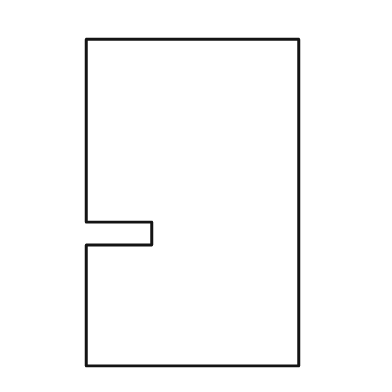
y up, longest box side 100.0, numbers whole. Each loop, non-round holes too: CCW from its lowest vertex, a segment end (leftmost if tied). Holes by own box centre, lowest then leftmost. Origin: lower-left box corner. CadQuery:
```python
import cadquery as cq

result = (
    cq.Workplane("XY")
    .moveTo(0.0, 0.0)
    .lineTo(65.0, 0.0)
    .lineTo(65.0, 100.0)
    .lineTo(0.0, 100.0)
    .lineTo(0.0, 44.0)
    .lineTo(20.0, 44.0)
    .lineTo(20.0, 37.0)
    .lineTo(0.0, 37.0)
    .close()
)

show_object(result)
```